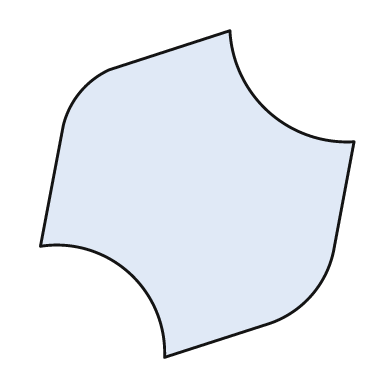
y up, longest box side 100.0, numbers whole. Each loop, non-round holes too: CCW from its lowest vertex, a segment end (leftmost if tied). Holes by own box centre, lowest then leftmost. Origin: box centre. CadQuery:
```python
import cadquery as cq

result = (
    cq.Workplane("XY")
    .moveTo(-10.0, -50.0)
    .lineTo(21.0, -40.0)
    .threePointArc((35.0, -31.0), (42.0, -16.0))
    .lineTo(48.0, 16.0)
    .threePointArc((22.0, 25.0), (10.0, 50.0))
    .lineTo(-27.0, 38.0)
    .threePointArc((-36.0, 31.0), (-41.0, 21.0))
    .lineTo(-48.0, -16.0)
    .threePointArc((-21.0, -24.0), (-10.0, -50.0))
    .close()
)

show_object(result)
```